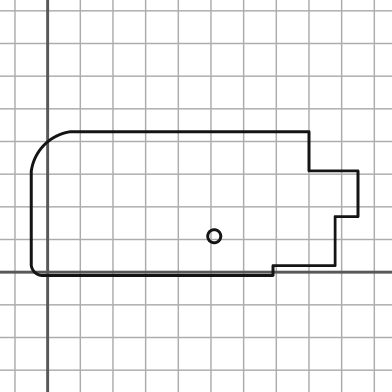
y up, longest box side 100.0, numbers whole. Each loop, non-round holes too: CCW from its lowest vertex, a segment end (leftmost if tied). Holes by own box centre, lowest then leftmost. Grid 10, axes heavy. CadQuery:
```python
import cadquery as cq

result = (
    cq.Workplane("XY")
    .moveTo(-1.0, -1.0)
    .lineTo(69.0, -1.0)
    .lineTo(69.0, 2.0)
    .lineTo(88.0, 2.0)
    .lineTo(88.0, 17.0)
    .lineTo(95.0, 17.0)
    .lineTo(95.0, 31.0)
    .lineTo(80.0, 31.0)
    .lineTo(80.0, 43.0)
    .lineTo(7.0, 43.0)
    .threePointArc((-1.0, 39.0), (-5.0, 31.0))
    .lineTo(-5.0, 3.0)
    .threePointArc((-4.0, 0.0), (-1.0, -1.0))
    .close()
    .moveTo(51.0, 11.0)
    .circle(2.0)
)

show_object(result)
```